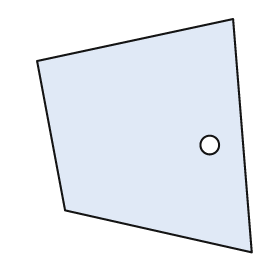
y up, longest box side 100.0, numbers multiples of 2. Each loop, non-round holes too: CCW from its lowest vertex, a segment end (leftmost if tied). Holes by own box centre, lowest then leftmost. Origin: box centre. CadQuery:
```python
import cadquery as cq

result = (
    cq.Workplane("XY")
    .moveTo(46.0, -50.0)
    .lineTo(38.0, 50.0)
    .lineTo(-46.0, 32.0)
    .lineTo(-34.0, -32.0)
    .close()
    .moveTo(28.0, -4.0)
    .circle(4.0)
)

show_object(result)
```